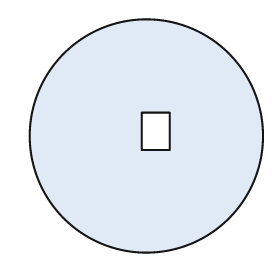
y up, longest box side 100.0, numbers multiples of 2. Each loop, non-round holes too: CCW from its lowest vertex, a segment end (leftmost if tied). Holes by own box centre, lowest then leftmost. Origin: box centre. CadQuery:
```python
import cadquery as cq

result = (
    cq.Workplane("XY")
    .moveTo(0.0, 0.0)
    .circle(50.0)
    .moveTo(-2.0, -6.0)
    .lineTo(10.0, -6.0)
    .lineTo(10.0, 10.0)
    .lineTo(-2.0, 10.0)
    .close()
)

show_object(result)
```